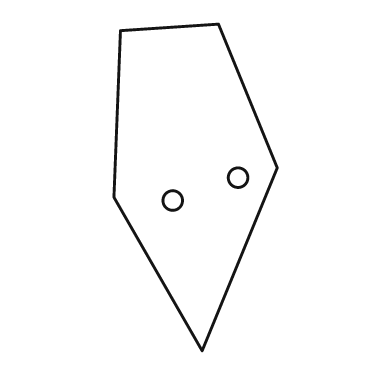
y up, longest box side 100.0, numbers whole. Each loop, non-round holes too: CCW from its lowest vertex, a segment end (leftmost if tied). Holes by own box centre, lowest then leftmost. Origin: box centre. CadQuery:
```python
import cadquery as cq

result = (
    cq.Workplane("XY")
    .moveTo(2.0, -50.0)
    .lineTo(25.0, 6.0)
    .lineTo(7.0, 50.0)
    .lineTo(-23.0, 48.0)
    .lineTo(-25.0, -3.0)
    .close()
    .moveTo(-7.0, -4.0)
    .circle(3.0)
    .moveTo(13.0, 3.0)
    .circle(3.0)
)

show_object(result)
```